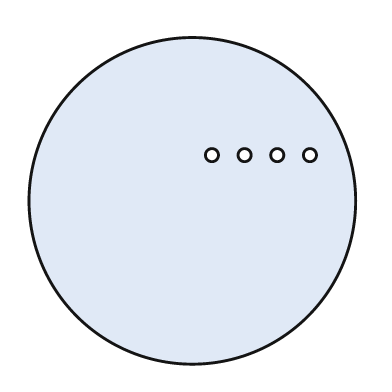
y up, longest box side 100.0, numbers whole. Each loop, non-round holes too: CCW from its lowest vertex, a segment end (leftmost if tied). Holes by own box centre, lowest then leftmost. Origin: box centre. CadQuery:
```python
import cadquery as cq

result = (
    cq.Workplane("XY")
    .moveTo(0.0, 0.0)
    .circle(50.0)
    .moveTo(6.0, 14.0)
    .circle(2.0)
    .moveTo(16.0, 14.0)
    .circle(2.0)
    .moveTo(26.0, 14.0)
    .circle(2.0)
    .moveTo(36.0, 14.0)
    .circle(2.0)
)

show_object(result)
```